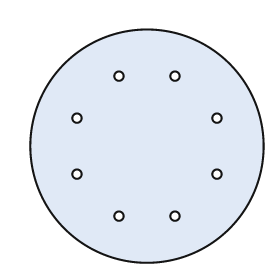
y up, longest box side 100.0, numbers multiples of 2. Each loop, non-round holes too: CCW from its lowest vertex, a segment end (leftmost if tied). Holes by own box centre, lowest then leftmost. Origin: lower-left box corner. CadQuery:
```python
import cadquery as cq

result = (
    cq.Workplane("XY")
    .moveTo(50.0, 50.0)
    .circle(50.0)
    .moveTo(38.0, 20.0)
    .circle(2.0)
    .moveTo(62.0, 20.0)
    .circle(2.0)
    .moveTo(20.0, 38.0)
    .circle(2.0)
    .moveTo(80.0, 38.0)
    .circle(2.0)
    .moveTo(20.0, 62.0)
    .circle(2.0)
    .moveTo(80.0, 62.0)
    .circle(2.0)
    .moveTo(38.0, 80.0)
    .circle(2.0)
    .moveTo(62.0, 80.0)
    .circle(2.0)
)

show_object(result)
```